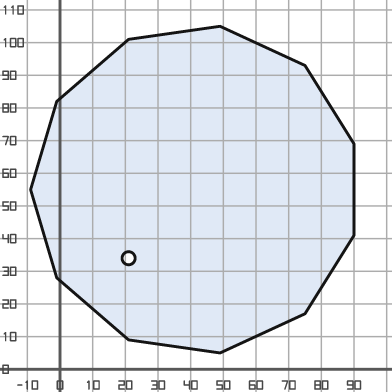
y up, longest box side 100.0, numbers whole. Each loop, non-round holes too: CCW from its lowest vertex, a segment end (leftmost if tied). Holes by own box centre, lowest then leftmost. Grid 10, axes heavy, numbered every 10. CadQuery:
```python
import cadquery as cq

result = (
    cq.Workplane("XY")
    .moveTo(49.0, 5.0)
    .lineTo(75.0, 17.0)
    .lineTo(90.0, 41.0)
    .lineTo(90.0, 69.0)
    .lineTo(75.0, 93.0)
    .lineTo(49.0, 105.0)
    .lineTo(21.0, 101.0)
    .lineTo(-1.0, 82.0)
    .lineTo(-9.0, 55.0)
    .lineTo(-1.0, 28.0)
    .lineTo(21.0, 9.0)
    .close()
    .moveTo(21.0, 34.0)
    .circle(2.0)
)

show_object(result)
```